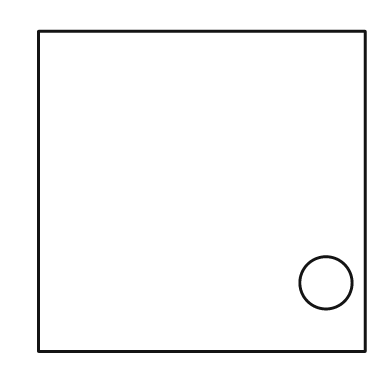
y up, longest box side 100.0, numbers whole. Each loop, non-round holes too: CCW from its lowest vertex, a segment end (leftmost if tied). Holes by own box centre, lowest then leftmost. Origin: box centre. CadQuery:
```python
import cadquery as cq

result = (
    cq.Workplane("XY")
    .moveTo(-50.0, -49.0)
    .lineTo(50.0, -49.0)
    .lineTo(50.0, 49.0)
    .lineTo(-50.0, 49.0)
    .close()
    .moveTo(38.0, -28.0)
    .circle(8.0)
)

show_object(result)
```